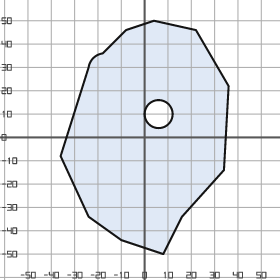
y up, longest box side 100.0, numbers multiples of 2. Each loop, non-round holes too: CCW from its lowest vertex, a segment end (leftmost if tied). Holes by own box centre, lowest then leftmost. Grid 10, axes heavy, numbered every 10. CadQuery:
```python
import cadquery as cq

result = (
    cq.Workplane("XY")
    .moveTo(8.0, -50.0)
    .lineTo(16.0, -34.0)
    .lineTo(34.0, -14.0)
    .lineTo(36.0, 22.0)
    .lineTo(22.0, 46.0)
    .lineTo(4.0, 50.0)
    .lineTo(-8.0, 46.0)
    .lineTo(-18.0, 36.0)
    .threePointArc((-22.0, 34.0), (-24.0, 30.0))
    .lineTo(-36.0, -8.0)
    .lineTo(-24.0, -34.0)
    .lineTo(-10.0, -44.0)
    .close()
    .moveTo(6.0, 10.0)
    .circle(6.0)
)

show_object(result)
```